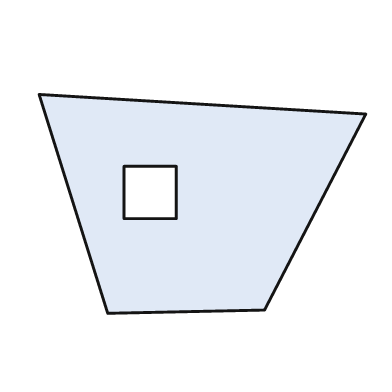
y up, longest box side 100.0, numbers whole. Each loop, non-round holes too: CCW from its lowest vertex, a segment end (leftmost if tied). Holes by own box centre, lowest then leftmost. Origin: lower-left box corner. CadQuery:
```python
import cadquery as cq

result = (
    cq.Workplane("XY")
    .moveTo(21.0, 0.0)
    .lineTo(69.0, 1.0)
    .lineTo(100.0, 61.0)
    .lineTo(0.0, 67.0)
    .close()
    .moveTo(26.0, 29.0)
    .lineTo(42.0, 29.0)
    .lineTo(42.0, 45.0)
    .lineTo(26.0, 45.0)
    .close()
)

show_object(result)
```